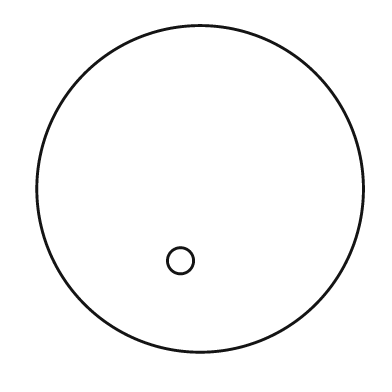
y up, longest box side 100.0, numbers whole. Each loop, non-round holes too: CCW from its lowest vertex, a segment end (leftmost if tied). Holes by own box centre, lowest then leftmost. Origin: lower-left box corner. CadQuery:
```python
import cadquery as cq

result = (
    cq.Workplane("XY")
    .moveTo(50.0, 50.0)
    .circle(50.0)
    .moveTo(44.0, 28.0)
    .circle(4.0)
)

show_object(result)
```